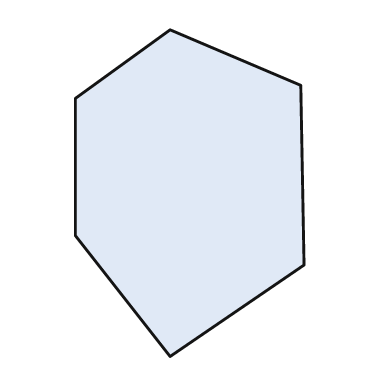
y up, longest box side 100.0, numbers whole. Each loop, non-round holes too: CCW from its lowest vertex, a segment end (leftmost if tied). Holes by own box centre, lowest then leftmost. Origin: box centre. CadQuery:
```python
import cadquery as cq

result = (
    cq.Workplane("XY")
    .moveTo(-6.0, -50.0)
    .lineTo(35.0, -22.0)
    .lineTo(34.0, 33.0)
    .lineTo(-6.0, 50.0)
    .lineTo(-35.0, 29.0)
    .lineTo(-35.0, -13.0)
    .close()
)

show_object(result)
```